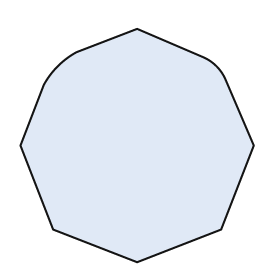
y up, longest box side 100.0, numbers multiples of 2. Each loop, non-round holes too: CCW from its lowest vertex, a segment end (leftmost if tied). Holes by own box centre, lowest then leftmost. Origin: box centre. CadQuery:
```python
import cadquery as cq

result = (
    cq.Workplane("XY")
    .moveTo(0.0, -50.0)
    .lineTo(36.0, -36.0)
    .lineTo(50.0, 0.0)
    .lineTo(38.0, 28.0)
    .threePointArc((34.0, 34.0), (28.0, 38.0))
    .lineTo(0.0, 50.0)
    .lineTo(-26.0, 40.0)
    .threePointArc((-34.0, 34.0), (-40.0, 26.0))
    .lineTo(-50.0, 0.0)
    .lineTo(-36.0, -36.0)
    .close()
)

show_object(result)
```